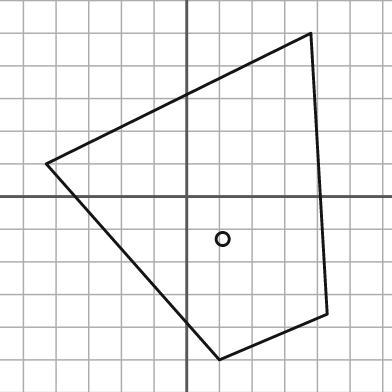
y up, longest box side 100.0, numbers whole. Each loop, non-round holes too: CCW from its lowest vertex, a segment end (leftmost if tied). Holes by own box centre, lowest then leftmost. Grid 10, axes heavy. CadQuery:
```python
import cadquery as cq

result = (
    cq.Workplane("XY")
    .moveTo(10.0, -50.0)
    .lineTo(43.0, -36.0)
    .lineTo(38.0, 50.0)
    .lineTo(-43.0, 10.0)
    .close()
    .moveTo(11.0, -13.0)
    .circle(2.0)
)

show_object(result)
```